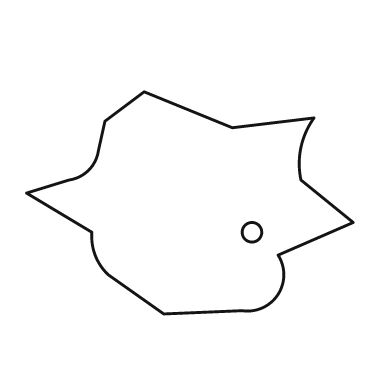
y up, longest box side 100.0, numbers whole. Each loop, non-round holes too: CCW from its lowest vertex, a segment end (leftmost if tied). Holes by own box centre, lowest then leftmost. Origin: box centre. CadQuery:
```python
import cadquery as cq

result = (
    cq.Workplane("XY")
    .moveTo(-8.0, -34.0)
    .lineTo(16.0, -33.0)
    .threePointArc((27.0, -28.0), (27.0, -16.0))
    .lineTo(50.0, -6.0)
    .lineTo(34.0, 7.0)
    .threePointArc((34.0, 17.0), (38.0, 26.0))
    .lineTo(13.0, 23.0)
    .lineTo(-14.0, 34.0)
    .lineTo(-26.0, 25.0)
    .lineTo(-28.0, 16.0)
    .threePointArc((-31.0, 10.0), (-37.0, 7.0))
    .lineTo(-50.0, 3.0)
    .lineTo(-30.0, -9.0)
    .threePointArc((-29.0, -16.0), (-25.0, -22.0))
    .close()
    .moveTo(19.0, -9.0)
    .circle(3.0)
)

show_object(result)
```